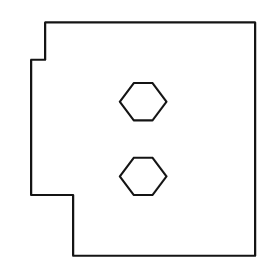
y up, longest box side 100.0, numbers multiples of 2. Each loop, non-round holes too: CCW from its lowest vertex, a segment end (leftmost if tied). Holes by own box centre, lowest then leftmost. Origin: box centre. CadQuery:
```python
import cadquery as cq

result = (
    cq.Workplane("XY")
    .moveTo(-30.0, -50.0)
    .lineTo(48.0, -50.0)
    .lineTo(48.0, 50.0)
    .lineTo(-42.0, 50.0)
    .lineTo(-42.0, 34.0)
    .lineTo(-48.0, 34.0)
    .lineTo(-48.0, -24.0)
    .lineTo(-30.0, -24.0)
    .close()
    .moveTo(-4.0, -24.0)
    .lineTo(4.0, -24.0)
    .lineTo(10.0, -16.0)
    .lineTo(4.0, -8.0)
    .lineTo(-4.0, -8.0)
    .lineTo(-10.0, -16.0)
    .close()
    .moveTo(-4.0, 8.0)
    .lineTo(4.0, 8.0)
    .lineTo(10.0, 16.0)
    .lineTo(4.0, 24.0)
    .lineTo(-4.0, 24.0)
    .lineTo(-10.0, 16.0)
    .close()
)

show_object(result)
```